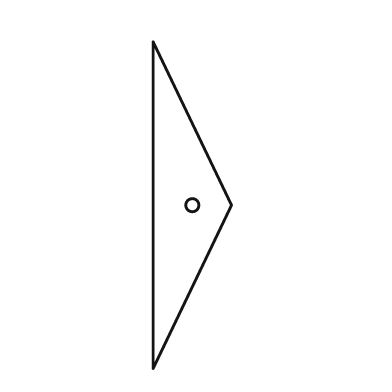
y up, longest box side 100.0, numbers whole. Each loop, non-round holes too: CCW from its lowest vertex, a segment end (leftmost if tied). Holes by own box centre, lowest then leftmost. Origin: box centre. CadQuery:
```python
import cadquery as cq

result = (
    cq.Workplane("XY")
    .moveTo(-12.0, -50.0)
    .lineTo(12.0, 0.0)
    .lineTo(-12.0, 50.0)
    .close()
    .moveTo(0.0, 0.0)
    .circle(2.0)
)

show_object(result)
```